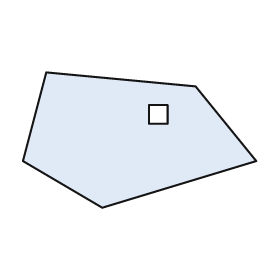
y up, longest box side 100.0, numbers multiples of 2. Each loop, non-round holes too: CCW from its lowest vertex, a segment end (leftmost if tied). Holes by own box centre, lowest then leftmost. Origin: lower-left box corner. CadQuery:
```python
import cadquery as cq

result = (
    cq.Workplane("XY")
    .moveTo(34.0, 0.0)
    .lineTo(100.0, 20.0)
    .lineTo(74.0, 52.0)
    .lineTo(10.0, 58.0)
    .lineTo(0.0, 20.0)
    .close()
    .moveTo(54.0, 36.0)
    .lineTo(62.0, 36.0)
    .lineTo(62.0, 44.0)
    .lineTo(54.0, 44.0)
    .close()
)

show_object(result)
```